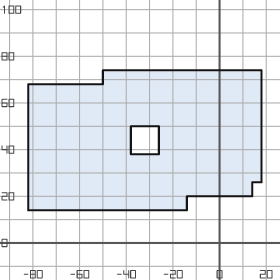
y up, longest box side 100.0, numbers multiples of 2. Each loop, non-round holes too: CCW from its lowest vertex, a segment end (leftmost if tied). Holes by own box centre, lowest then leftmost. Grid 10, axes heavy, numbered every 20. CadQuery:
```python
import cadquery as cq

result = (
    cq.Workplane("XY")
    .moveTo(-82.0, 14.0)
    .lineTo(-14.0, 14.0)
    .lineTo(-14.0, 20.0)
    .lineTo(14.0, 20.0)
    .lineTo(14.0, 26.0)
    .lineTo(18.0, 26.0)
    .lineTo(18.0, 74.0)
    .lineTo(-50.0, 74.0)
    .lineTo(-50.0, 68.0)
    .lineTo(-82.0, 68.0)
    .close()
    .moveTo(-38.0, 38.0)
    .lineTo(-26.0, 38.0)
    .lineTo(-26.0, 50.0)
    .lineTo(-38.0, 50.0)
    .close()
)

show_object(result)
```